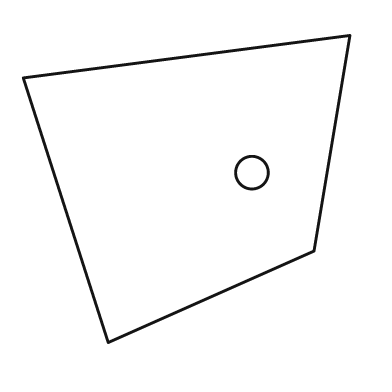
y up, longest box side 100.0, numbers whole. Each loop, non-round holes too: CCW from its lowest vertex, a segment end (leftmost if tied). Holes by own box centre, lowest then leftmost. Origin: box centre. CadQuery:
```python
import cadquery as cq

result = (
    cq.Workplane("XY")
    .moveTo(-24.0, -47.0)
    .lineTo(39.0, -19.0)
    .lineTo(50.0, 47.0)
    .lineTo(-50.0, 34.0)
    .close()
    .moveTo(20.0, 5.0)
    .circle(5.0)
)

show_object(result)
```